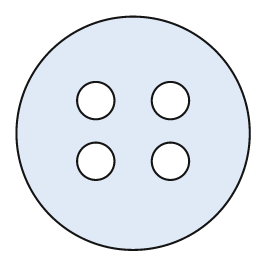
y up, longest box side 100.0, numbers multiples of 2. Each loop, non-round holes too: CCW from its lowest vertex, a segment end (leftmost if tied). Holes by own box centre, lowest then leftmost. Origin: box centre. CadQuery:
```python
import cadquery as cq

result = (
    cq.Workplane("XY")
    .moveTo(0.0, 0.0)
    .circle(50.0)
    .moveTo(-16.0, -12.0)
    .circle(8.0)
    .moveTo(16.0, -12.0)
    .circle(8.0)
    .moveTo(-16.0, 14.0)
    .circle(8.0)
    .moveTo(16.0, 14.0)
    .circle(8.0)
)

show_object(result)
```